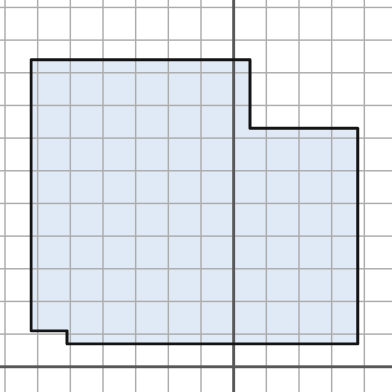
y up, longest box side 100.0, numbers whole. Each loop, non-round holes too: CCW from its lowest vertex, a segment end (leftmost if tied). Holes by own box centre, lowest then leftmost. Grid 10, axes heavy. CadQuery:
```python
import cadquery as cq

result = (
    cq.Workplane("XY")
    .moveTo(-51.0, 7.0)
    .lineTo(38.0, 7.0)
    .lineTo(38.0, 73.0)
    .lineTo(5.0, 73.0)
    .lineTo(5.0, 94.0)
    .lineTo(-62.0, 94.0)
    .lineTo(-62.0, 11.0)
    .lineTo(-51.0, 11.0)
    .close()
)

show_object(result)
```